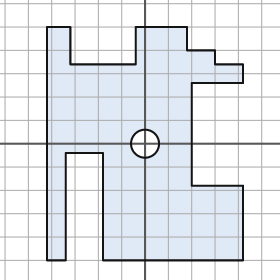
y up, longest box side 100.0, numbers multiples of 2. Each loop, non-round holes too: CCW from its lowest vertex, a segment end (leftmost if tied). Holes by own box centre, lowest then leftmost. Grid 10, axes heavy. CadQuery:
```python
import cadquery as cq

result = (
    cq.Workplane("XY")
    .moveTo(-42.0, -50.0)
    .lineTo(-34.0, -50.0)
    .lineTo(-34.0, -4.0)
    .lineTo(-18.0, -4.0)
    .lineTo(-18.0, -50.0)
    .lineTo(42.0, -50.0)
    .lineTo(42.0, -18.0)
    .lineTo(20.0, -18.0)
    .lineTo(20.0, 26.0)
    .lineTo(42.0, 26.0)
    .lineTo(42.0, 34.0)
    .lineTo(30.0, 34.0)
    .lineTo(30.0, 40.0)
    .lineTo(18.0, 40.0)
    .lineTo(18.0, 50.0)
    .lineTo(-4.0, 50.0)
    .lineTo(-4.0, 34.0)
    .lineTo(-32.0, 34.0)
    .lineTo(-32.0, 50.0)
    .lineTo(-42.0, 50.0)
    .close()
    .moveTo(0.0, 0.0)
    .circle(6.0)
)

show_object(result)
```